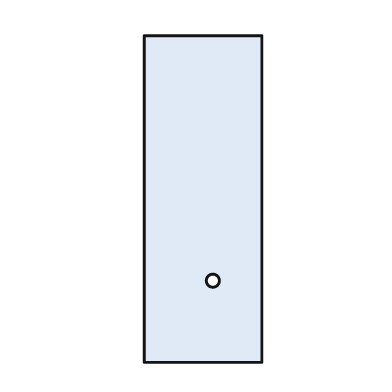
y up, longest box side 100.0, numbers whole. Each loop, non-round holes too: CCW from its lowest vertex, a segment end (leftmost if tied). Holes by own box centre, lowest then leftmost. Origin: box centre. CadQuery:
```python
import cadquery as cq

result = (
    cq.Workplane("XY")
    .moveTo(-18.0, -50.0)
    .lineTo(18.0, -50.0)
    .lineTo(18.0, 50.0)
    .lineTo(-18.0, 50.0)
    .close()
    .moveTo(3.0, -25.0)
    .circle(2.0)
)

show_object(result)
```